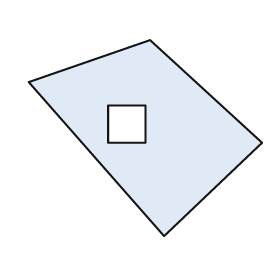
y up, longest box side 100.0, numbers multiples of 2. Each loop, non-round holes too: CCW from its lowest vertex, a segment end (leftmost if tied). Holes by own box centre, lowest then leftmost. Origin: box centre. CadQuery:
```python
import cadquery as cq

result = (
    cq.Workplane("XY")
    .moveTo(8.0, -42.0)
    .lineTo(50.0, -2.0)
    .lineTo(2.0, 42.0)
    .lineTo(-50.0, 24.0)
    .close()
    .moveTo(-16.0, -2.0)
    .lineTo(0.0, -2.0)
    .lineTo(0.0, 14.0)
    .lineTo(-16.0, 14.0)
    .close()
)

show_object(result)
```